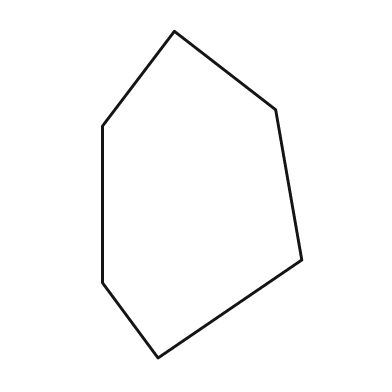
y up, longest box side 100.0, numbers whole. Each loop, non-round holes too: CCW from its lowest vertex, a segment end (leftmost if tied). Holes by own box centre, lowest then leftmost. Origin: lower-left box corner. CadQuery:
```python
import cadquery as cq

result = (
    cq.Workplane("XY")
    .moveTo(17.0, 0.0)
    .lineTo(61.0, 30.0)
    .lineTo(53.0, 76.0)
    .lineTo(22.0, 100.0)
    .lineTo(0.0, 71.0)
    .lineTo(0.0, 23.0)
    .close()
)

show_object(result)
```